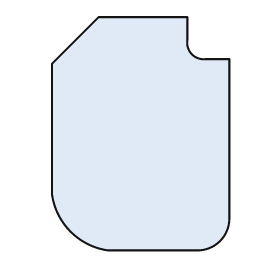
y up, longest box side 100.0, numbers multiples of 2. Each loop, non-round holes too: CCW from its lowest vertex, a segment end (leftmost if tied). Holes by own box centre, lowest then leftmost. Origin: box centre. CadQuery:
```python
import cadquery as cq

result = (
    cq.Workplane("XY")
    .moveTo(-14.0, -50.0)
    .lineTo(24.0, -50.0)
    .threePointArc((34.0, -46.0), (38.0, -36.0))
    .lineTo(38.0, 32.0)
    .lineTo(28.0, 32.0)
    .threePointArc((22.0, 34.0), (20.0, 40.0))
    .lineTo(20.0, 50.0)
    .lineTo(-18.0, 50.0)
    .lineTo(-38.0, 30.0)
    .lineTo(-38.0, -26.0)
    .threePointArc((-30.0, -42.0), (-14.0, -50.0))
    .close()
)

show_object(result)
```